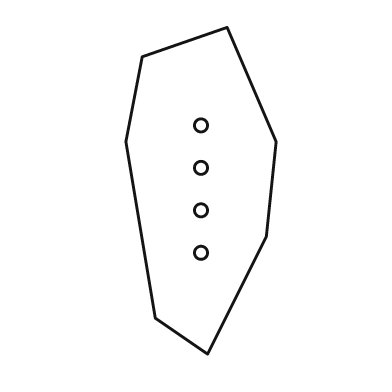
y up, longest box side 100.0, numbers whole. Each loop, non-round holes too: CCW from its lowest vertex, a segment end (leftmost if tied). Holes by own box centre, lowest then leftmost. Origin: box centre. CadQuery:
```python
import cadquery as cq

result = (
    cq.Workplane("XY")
    .moveTo(2.0, -50.0)
    .lineTo(20.0, -14.0)
    .lineTo(23.0, 15.0)
    .lineTo(8.0, 50.0)
    .lineTo(-18.0, 41.0)
    .lineTo(-23.0, 15.0)
    .lineTo(-14.0, -39.0)
    .close()
    .moveTo(0.0, -19.0)
    .circle(2.0)
    .moveTo(0.0, -6.0)
    .circle(2.0)
    .moveTo(0.0, 7.0)
    .circle(2.0)
    .moveTo(0.0, 20.0)
    .circle(2.0)
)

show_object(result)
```